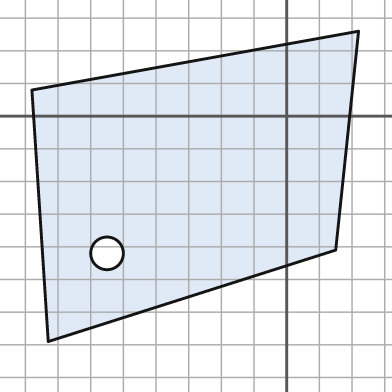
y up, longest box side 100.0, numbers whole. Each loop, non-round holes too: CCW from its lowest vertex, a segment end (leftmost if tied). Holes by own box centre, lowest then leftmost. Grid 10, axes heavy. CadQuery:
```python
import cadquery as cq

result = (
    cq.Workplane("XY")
    .moveTo(-73.0, -69.0)
    .lineTo(15.0, -41.0)
    .lineTo(22.0, 26.0)
    .lineTo(-78.0, 8.0)
    .close()
    .moveTo(-55.0, -42.0)
    .circle(5.0)
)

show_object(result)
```